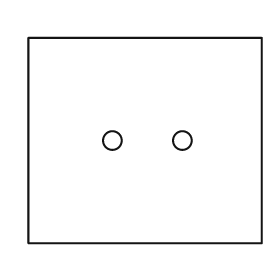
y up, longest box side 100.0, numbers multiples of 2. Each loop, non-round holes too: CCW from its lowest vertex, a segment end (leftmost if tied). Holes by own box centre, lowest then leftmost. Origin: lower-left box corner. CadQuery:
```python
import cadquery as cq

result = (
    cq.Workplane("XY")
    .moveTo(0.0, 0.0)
    .lineTo(100.0, 0.0)
    .lineTo(100.0, 88.0)
    .lineTo(0.0, 88.0)
    .close()
    .moveTo(36.0, 44.0)
    .circle(4.0)
    .moveTo(66.0, 44.0)
    .circle(4.0)
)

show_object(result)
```